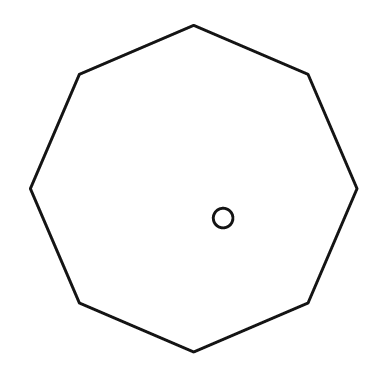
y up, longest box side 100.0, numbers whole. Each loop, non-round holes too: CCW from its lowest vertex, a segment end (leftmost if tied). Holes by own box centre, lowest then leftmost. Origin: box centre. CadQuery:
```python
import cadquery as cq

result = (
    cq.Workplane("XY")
    .moveTo(0.0, -50.0)
    .lineTo(35.0, -35.0)
    .lineTo(50.0, 0.0)
    .lineTo(35.0, 35.0)
    .lineTo(0.0, 50.0)
    .lineTo(-35.0, 35.0)
    .lineTo(-50.0, 0.0)
    .lineTo(-35.0, -35.0)
    .close()
    .moveTo(9.0, -9.0)
    .circle(3.0)
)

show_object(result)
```